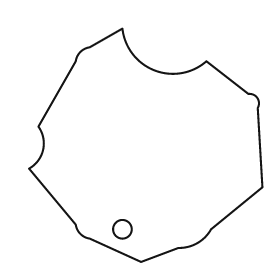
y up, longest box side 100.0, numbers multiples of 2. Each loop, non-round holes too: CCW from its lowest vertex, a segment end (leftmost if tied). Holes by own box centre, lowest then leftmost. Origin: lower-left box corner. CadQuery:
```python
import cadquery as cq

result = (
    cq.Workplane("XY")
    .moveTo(48.0, 0.0)
    .lineTo(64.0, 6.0)
    .threePointArc((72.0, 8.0), (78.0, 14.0))
    .lineTo(100.0, 32.0)
    .lineTo(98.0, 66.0)
    .threePointArc((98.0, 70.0), (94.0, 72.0))
    .lineTo(76.0, 86.0)
    .threePointArc((54.0, 82.0), (40.0, 100.0))
    .lineTo(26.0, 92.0)
    .threePointArc((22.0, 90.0), (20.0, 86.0))
    .lineTo(4.0, 58.0)
    .threePointArc((6.0, 48.0), (0.0, 40.0))
    .lineTo(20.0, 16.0)
    .threePointArc((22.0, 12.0), (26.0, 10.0))
    .close()
    .moveTo(40.0, 14.0)
    .circle(4.0)
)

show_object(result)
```